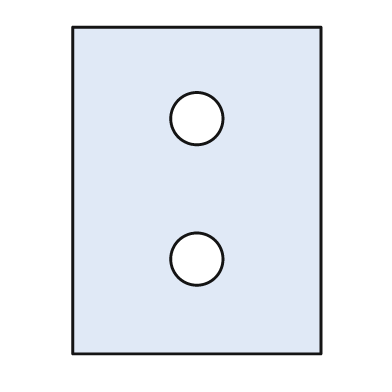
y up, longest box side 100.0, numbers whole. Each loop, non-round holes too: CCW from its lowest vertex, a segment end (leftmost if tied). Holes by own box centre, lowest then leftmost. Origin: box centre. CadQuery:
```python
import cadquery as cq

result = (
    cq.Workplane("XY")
    .moveTo(-38.0, -50.0)
    .lineTo(38.0, -50.0)
    .lineTo(38.0, 50.0)
    .lineTo(-38.0, 50.0)
    .close()
    .moveTo(0.0, -21.0)
    .circle(8.0)
    .moveTo(0.0, 22.0)
    .circle(8.0)
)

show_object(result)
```